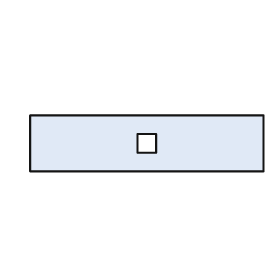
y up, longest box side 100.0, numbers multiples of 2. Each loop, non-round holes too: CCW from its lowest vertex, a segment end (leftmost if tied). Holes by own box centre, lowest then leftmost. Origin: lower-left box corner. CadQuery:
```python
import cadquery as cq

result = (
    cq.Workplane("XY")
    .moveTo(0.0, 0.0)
    .lineTo(100.0, 0.0)
    .lineTo(100.0, 24.0)
    .lineTo(0.0, 24.0)
    .close()
    .moveTo(46.0, 8.0)
    .lineTo(54.0, 8.0)
    .lineTo(54.0, 16.0)
    .lineTo(46.0, 16.0)
    .close()
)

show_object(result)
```